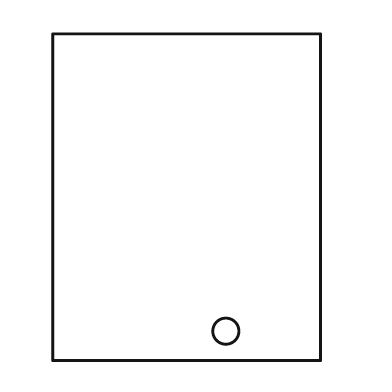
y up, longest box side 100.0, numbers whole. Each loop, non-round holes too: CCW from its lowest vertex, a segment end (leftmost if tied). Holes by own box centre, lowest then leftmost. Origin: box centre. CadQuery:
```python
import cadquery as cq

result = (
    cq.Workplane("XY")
    .moveTo(-41.0, -50.0)
    .lineTo(41.0, -50.0)
    .lineTo(41.0, 50.0)
    .lineTo(-41.0, 50.0)
    .close()
    .moveTo(12.0, -41.0)
    .circle(4.0)
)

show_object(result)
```